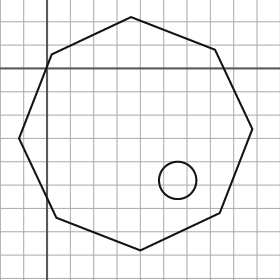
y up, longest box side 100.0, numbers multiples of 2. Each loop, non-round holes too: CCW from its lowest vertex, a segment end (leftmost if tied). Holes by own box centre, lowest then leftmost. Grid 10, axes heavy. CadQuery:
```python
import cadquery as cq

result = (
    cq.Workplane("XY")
    .moveTo(40.0, -78.0)
    .lineTo(74.0, -62.0)
    .lineTo(88.0, -26.0)
    .lineTo(72.0, 8.0)
    .lineTo(36.0, 22.0)
    .lineTo(2.0, 6.0)
    .lineTo(-12.0, -30.0)
    .lineTo(4.0, -64.0)
    .close()
    .moveTo(56.0, -48.0)
    .circle(8.0)
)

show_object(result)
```